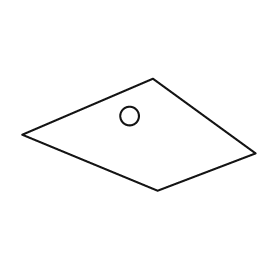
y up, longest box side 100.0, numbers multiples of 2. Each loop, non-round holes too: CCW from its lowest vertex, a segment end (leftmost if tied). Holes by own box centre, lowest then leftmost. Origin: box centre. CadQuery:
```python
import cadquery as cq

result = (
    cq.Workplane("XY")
    .moveTo(8.0, -24.0)
    .lineTo(50.0, -8.0)
    .lineTo(6.0, 24.0)
    .lineTo(-50.0, 0.0)
    .close()
    .moveTo(-4.0, 8.0)
    .circle(4.0)
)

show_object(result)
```